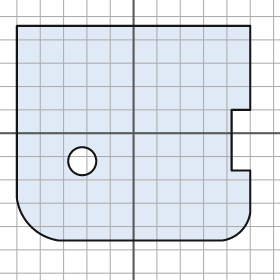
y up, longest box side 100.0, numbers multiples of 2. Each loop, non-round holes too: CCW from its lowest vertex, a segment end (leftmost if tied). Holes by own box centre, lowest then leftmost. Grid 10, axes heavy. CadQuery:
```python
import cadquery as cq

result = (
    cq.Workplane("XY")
    .moveTo(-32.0, -46.0)
    .lineTo(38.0, -46.0)
    .threePointArc((46.0, -42.0), (50.0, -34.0))
    .lineTo(50.0, -16.0)
    .lineTo(42.0, -16.0)
    .lineTo(42.0, 10.0)
    .lineTo(50.0, 10.0)
    .lineTo(50.0, 46.0)
    .lineTo(-50.0, 46.0)
    .lineTo(-50.0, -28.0)
    .threePointArc((-44.0, -40.0), (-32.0, -46.0))
    .close()
    .moveTo(-22.0, -12.0)
    .circle(6.0)
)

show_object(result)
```